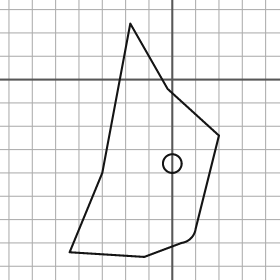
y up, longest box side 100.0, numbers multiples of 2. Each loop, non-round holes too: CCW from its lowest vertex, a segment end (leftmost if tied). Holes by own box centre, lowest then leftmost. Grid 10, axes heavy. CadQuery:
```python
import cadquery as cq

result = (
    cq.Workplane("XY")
    .moveTo(-12.0, -76.0)
    .lineTo(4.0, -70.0)
    .threePointArc((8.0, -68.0), (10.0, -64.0))
    .lineTo(20.0, -24.0)
    .lineTo(-2.0, -4.0)
    .lineTo(-18.0, 24.0)
    .lineTo(-30.0, -40.0)
    .lineTo(-44.0, -74.0)
    .close()
    .moveTo(0.0, -36.0)
    .circle(4.0)
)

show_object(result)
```